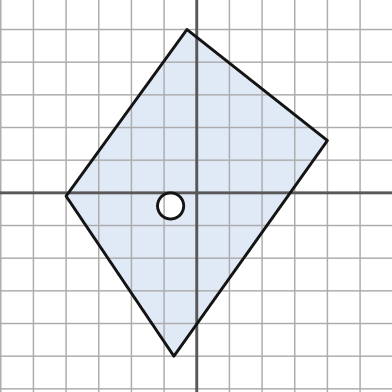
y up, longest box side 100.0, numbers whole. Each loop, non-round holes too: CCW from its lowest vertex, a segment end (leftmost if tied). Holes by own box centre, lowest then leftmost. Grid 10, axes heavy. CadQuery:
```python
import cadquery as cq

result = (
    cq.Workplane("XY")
    .moveTo(-7.0, -50.0)
    .lineTo(40.0, 16.0)
    .lineTo(-3.0, 50.0)
    .lineTo(-40.0, -1.0)
    .close()
    .moveTo(-8.0, -4.0)
    .circle(4.0)
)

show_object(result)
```